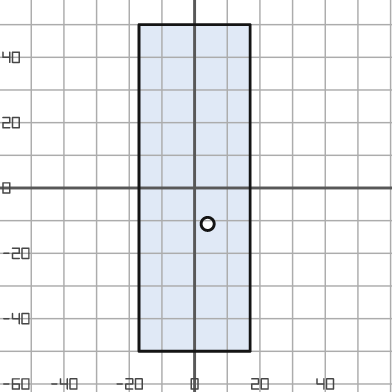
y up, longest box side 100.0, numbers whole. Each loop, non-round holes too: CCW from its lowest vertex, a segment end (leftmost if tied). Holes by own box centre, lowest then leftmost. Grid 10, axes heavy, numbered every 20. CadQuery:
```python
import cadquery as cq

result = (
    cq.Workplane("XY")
    .moveTo(-17.0, -50.0)
    .lineTo(17.0, -50.0)
    .lineTo(17.0, 50.0)
    .lineTo(-17.0, 50.0)
    .close()
    .moveTo(4.0, -11.0)
    .circle(2.0)
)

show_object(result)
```